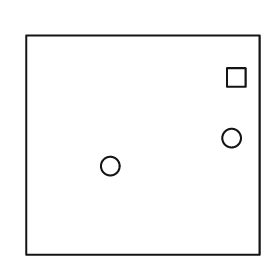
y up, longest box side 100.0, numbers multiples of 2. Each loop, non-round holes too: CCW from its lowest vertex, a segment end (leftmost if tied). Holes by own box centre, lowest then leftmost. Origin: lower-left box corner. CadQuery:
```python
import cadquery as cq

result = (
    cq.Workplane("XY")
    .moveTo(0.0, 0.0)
    .lineTo(100.0, 0.0)
    .lineTo(100.0, 94.0)
    .lineTo(0.0, 94.0)
    .close()
    .moveTo(36.0, 38.0)
    .circle(4.0)
    .moveTo(88.0, 50.0)
    .circle(4.0)
    .moveTo(86.0, 72.0)
    .lineTo(94.0, 72.0)
    .lineTo(94.0, 80.0)
    .lineTo(86.0, 80.0)
    .close()
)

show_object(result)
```